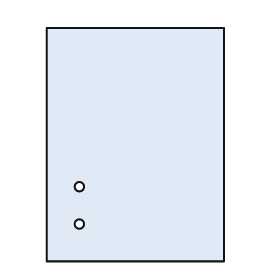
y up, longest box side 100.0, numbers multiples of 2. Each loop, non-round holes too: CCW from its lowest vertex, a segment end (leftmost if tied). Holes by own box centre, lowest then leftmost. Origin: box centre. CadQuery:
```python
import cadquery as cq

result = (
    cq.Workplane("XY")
    .moveTo(-38.0, -50.0)
    .lineTo(38.0, -50.0)
    .lineTo(38.0, 50.0)
    .lineTo(-38.0, 50.0)
    .close()
    .moveTo(-24.0, -34.0)
    .circle(2.0)
    .moveTo(-24.0, -18.0)
    .circle(2.0)
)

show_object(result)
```